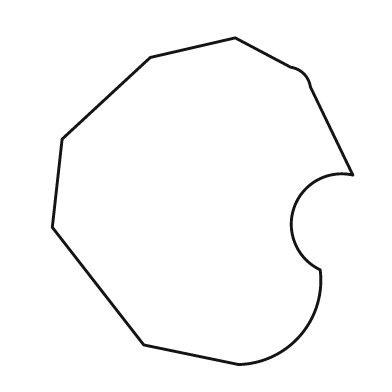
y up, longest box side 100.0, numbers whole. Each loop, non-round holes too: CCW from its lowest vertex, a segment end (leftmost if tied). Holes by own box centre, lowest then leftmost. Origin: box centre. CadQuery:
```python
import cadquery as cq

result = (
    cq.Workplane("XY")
    .moveTo(11.0, -50.0)
    .threePointArc((30.0, -41.0), (36.0, -21.0))
    .threePointArc((28.0, -2.0), (46.0, 8.0))
    .lineTo(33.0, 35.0)
    .threePointArc((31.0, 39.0), (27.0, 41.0))
    .lineTo(10.0, 50.0)
    .lineTo(-16.0, 44.0)
    .lineTo(-43.0, 19.0)
    .lineTo(-46.0, -8.0)
    .lineTo(-18.0, -44.0)
    .close()
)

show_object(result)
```